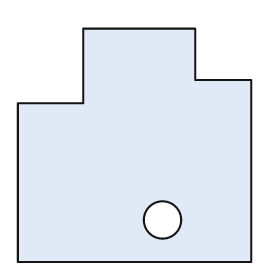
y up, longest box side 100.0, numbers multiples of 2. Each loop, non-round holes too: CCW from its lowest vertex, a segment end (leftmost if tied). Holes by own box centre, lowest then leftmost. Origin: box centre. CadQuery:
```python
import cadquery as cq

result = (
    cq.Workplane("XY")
    .moveTo(-50.0, -50.0)
    .lineTo(50.0, -50.0)
    .lineTo(50.0, 28.0)
    .lineTo(26.0, 28.0)
    .lineTo(26.0, 50.0)
    .lineTo(-22.0, 50.0)
    .lineTo(-22.0, 18.0)
    .lineTo(-50.0, 18.0)
    .close()
    .moveTo(12.0, -32.0)
    .circle(8.0)
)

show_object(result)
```